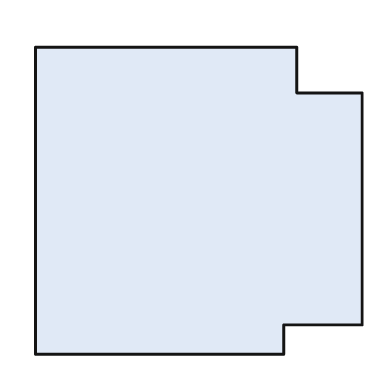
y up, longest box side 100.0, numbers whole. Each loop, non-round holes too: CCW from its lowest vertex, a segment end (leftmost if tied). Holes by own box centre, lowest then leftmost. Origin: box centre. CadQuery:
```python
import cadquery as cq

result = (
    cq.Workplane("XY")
    .moveTo(-50.0, -47.0)
    .lineTo(26.0, -47.0)
    .lineTo(26.0, -38.0)
    .lineTo(50.0, -38.0)
    .lineTo(50.0, 33.0)
    .lineTo(30.0, 33.0)
    .lineTo(30.0, 47.0)
    .lineTo(-50.0, 47.0)
    .close()
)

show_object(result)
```